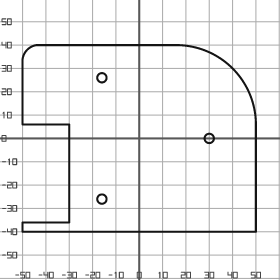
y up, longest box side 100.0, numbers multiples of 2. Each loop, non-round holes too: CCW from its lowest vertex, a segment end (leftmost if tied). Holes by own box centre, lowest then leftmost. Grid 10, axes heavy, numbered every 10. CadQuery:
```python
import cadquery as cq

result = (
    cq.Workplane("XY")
    .moveTo(-50.0, -40.0)
    .lineTo(50.0, -40.0)
    .lineTo(50.0, 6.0)
    .threePointArc((40.0, 30.0), (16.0, 40.0))
    .lineTo(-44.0, 40.0)
    .threePointArc((-48.0, 38.0), (-50.0, 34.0))
    .lineTo(-50.0, 6.0)
    .lineTo(-30.0, 6.0)
    .lineTo(-30.0, -36.0)
    .lineTo(-50.0, -36.0)
    .close()
    .moveTo(-16.0, -26.0)
    .circle(2.0)
    .moveTo(30.0, 0.0)
    .circle(2.0)
    .moveTo(-16.0, 26.0)
    .circle(2.0)
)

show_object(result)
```